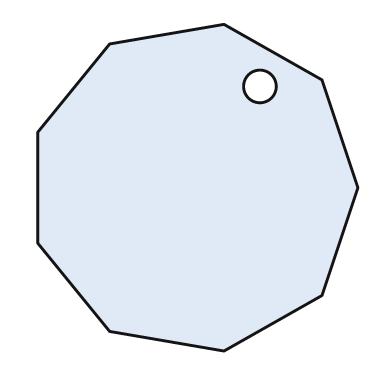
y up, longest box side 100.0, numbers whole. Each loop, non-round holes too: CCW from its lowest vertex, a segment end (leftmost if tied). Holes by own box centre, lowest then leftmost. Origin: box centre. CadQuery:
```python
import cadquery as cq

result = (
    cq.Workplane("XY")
    .moveTo(8.0, -50.0)
    .lineTo(38.0, -33.0)
    .lineTo(49.0, 0.0)
    .lineTo(38.0, 33.0)
    .lineTo(8.0, 50.0)
    .lineTo(-27.0, 44.0)
    .lineTo(-49.0, 17.0)
    .lineTo(-49.0, -17.0)
    .lineTo(-27.0, -44.0)
    .close()
    .moveTo(19.0, 31.0)
    .circle(5.0)
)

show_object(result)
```